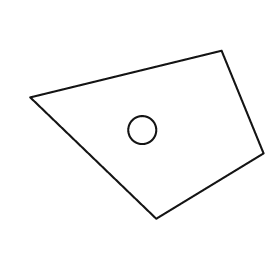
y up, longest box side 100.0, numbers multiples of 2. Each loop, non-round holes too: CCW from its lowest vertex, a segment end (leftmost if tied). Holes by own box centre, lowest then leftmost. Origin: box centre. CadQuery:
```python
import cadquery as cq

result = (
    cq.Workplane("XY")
    .moveTo(4.0, -36.0)
    .lineTo(50.0, -8.0)
    .lineTo(32.0, 36.0)
    .lineTo(-50.0, 16.0)
    .close()
    .moveTo(-2.0, 2.0)
    .circle(6.0)
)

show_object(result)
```